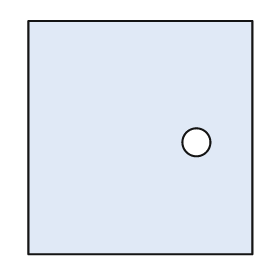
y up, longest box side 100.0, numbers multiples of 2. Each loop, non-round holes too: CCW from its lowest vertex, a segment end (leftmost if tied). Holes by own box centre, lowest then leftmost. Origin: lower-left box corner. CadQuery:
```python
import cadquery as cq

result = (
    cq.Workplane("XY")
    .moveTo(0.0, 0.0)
    .lineTo(96.0, 0.0)
    .lineTo(96.0, 100.0)
    .lineTo(0.0, 100.0)
    .close()
    .moveTo(72.0, 48.0)
    .circle(6.0)
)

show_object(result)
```